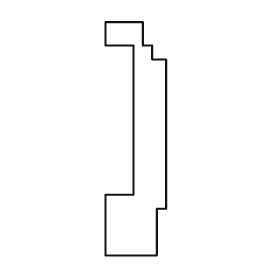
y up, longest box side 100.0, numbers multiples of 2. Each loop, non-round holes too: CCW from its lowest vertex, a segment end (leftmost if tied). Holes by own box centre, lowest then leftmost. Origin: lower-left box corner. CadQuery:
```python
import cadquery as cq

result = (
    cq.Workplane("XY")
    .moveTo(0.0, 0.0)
    .lineTo(22.0, 0.0)
    .lineTo(22.0, 20.0)
    .lineTo(26.0, 20.0)
    .lineTo(26.0, 84.0)
    .lineTo(20.0, 84.0)
    .lineTo(20.0, 90.0)
    .lineTo(16.0, 90.0)
    .lineTo(16.0, 100.0)
    .lineTo(0.0, 100.0)
    .lineTo(0.0, 90.0)
    .lineTo(12.0, 90.0)
    .lineTo(12.0, 26.0)
    .lineTo(0.0, 26.0)
    .close()
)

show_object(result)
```